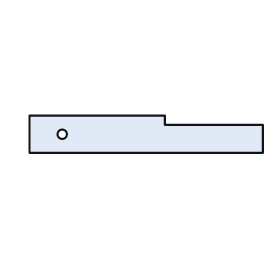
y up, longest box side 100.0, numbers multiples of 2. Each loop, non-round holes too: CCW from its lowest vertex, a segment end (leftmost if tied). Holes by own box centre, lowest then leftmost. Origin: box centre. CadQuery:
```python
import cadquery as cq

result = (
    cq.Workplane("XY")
    .moveTo(-50.0, -8.0)
    .lineTo(50.0, -8.0)
    .lineTo(50.0, 4.0)
    .lineTo(8.0, 4.0)
    .lineTo(8.0, 8.0)
    .lineTo(-50.0, 8.0)
    .close()
    .moveTo(-36.0, 0.0)
    .circle(2.0)
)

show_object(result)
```